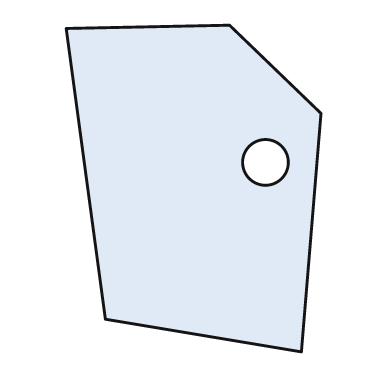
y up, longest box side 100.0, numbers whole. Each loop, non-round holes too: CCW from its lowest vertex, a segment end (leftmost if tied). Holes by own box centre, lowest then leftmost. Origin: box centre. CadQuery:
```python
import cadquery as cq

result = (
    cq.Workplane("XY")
    .moveTo(33.0, -50.0)
    .lineTo(39.0, 23.0)
    .lineTo(11.0, 50.0)
    .lineTo(-39.0, 49.0)
    .lineTo(-27.0, -40.0)
    .close()
    .moveTo(22.0, 8.0)
    .circle(7.0)
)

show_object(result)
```